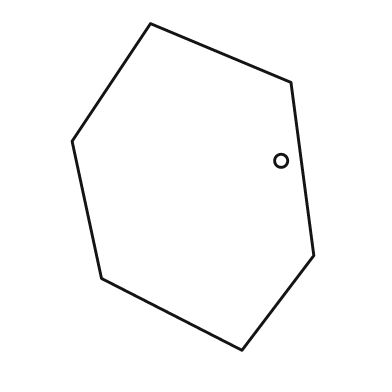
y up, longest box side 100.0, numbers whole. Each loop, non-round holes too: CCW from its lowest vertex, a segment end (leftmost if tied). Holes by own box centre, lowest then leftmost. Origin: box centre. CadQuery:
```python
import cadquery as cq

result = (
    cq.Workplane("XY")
    .moveTo(15.0, -50.0)
    .lineTo(37.0, -21.0)
    .lineTo(30.0, 32.0)
    .lineTo(-13.0, 50.0)
    .lineTo(-37.0, 14.0)
    .lineTo(-28.0, -28.0)
    .close()
    .moveTo(27.0, 8.0)
    .circle(2.0)
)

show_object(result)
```